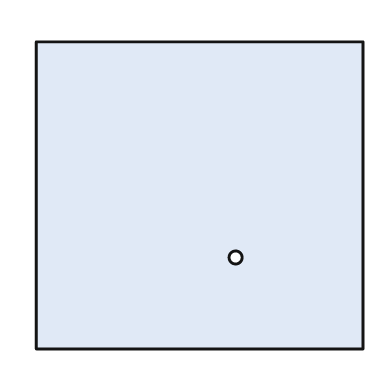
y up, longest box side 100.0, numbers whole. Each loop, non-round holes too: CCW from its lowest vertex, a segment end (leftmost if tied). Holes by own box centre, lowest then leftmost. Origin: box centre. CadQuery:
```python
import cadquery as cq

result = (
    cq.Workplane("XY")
    .moveTo(-50.0, -47.0)
    .lineTo(50.0, -47.0)
    .lineTo(50.0, 47.0)
    .lineTo(-50.0, 47.0)
    .close()
    .moveTo(11.0, -19.0)
    .circle(2.0)
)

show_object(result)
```